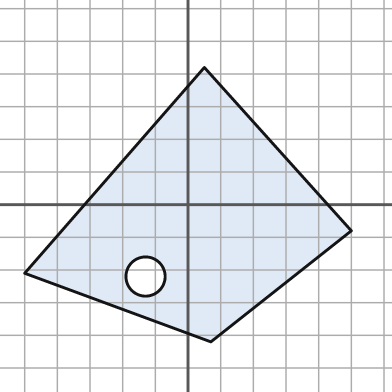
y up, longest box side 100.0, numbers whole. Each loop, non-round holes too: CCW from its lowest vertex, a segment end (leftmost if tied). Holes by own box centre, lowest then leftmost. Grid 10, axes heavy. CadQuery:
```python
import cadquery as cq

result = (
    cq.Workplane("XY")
    .moveTo(7.0, -42.0)
    .lineTo(50.0, -8.0)
    .lineTo(5.0, 42.0)
    .lineTo(-50.0, -21.0)
    .close()
    .moveTo(-13.0, -22.0)
    .circle(6.0)
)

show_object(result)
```